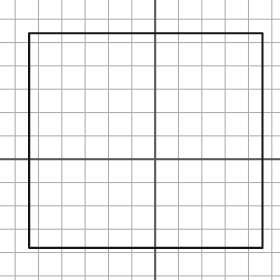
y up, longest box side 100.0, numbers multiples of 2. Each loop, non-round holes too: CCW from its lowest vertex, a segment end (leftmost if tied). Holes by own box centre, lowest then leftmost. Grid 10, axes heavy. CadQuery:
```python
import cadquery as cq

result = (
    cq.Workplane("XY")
    .moveTo(-54.0, -38.0)
    .lineTo(46.0, -38.0)
    .lineTo(46.0, 54.0)
    .lineTo(-54.0, 54.0)
    .close()
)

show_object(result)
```